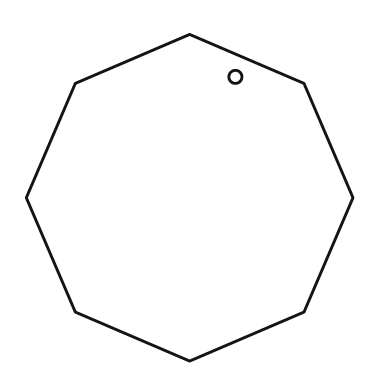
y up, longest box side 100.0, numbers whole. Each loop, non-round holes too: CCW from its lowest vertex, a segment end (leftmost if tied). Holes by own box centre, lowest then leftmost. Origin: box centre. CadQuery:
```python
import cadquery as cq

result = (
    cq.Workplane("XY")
    .moveTo(0.0, -50.0)
    .lineTo(35.0, -35.0)
    .lineTo(50.0, 0.0)
    .lineTo(35.0, 35.0)
    .lineTo(0.0, 50.0)
    .lineTo(-35.0, 35.0)
    .lineTo(-50.0, 0.0)
    .lineTo(-35.0, -35.0)
    .close()
    .moveTo(14.0, 37.0)
    .circle(2.0)
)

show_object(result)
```